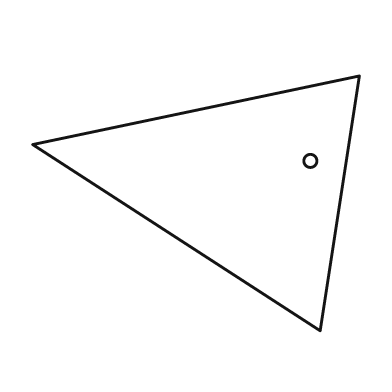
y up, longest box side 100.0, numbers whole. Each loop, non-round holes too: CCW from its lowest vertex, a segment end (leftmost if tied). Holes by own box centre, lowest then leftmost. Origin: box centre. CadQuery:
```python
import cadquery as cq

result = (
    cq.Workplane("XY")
    .moveTo(38.0, -39.0)
    .lineTo(50.0, 39.0)
    .lineTo(-50.0, 18.0)
    .close()
    .moveTo(35.0, 13.0)
    .circle(2.0)
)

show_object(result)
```